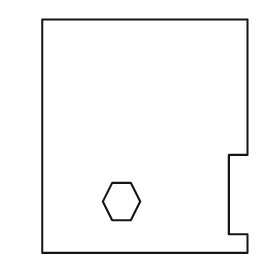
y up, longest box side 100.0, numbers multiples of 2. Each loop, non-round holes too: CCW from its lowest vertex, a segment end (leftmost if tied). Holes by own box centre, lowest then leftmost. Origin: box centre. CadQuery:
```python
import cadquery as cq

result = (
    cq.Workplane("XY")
    .moveTo(-44.0, -50.0)
    .lineTo(44.0, -50.0)
    .lineTo(44.0, -42.0)
    .lineTo(36.0, -42.0)
    .lineTo(36.0, -8.0)
    .lineTo(44.0, -8.0)
    .lineTo(44.0, 50.0)
    .lineTo(-44.0, 50.0)
    .close()
    .moveTo(-14.0, -36.0)
    .lineTo(-6.0, -36.0)
    .lineTo(-2.0, -28.0)
    .lineTo(-6.0, -20.0)
    .lineTo(-14.0, -20.0)
    .lineTo(-18.0, -28.0)
    .close()
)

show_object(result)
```